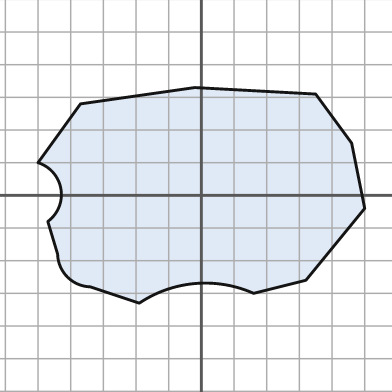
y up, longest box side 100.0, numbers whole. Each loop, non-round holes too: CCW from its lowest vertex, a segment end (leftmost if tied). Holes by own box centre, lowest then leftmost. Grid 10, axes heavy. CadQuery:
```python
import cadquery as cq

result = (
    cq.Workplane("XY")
    .moveTo(-19.0, -33.0)
    .threePointArc((-2.0, -27.0), (16.0, -30.0))
    .lineTo(32.0, -26.0)
    .lineTo(50.0, -4.0)
    .lineTo(46.0, 16.0)
    .lineTo(35.0, 31.0)
    .lineTo(-2.0, 33.0)
    .lineTo(-37.0, 28.0)
    .lineTo(-50.0, 10.0)
    .threePointArc((-43.0, 2.0), (-47.0, -8.0))
    .lineTo(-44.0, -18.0)
    .threePointArc((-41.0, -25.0), (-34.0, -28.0))
    .close()
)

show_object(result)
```